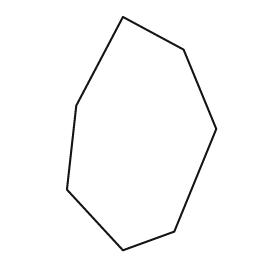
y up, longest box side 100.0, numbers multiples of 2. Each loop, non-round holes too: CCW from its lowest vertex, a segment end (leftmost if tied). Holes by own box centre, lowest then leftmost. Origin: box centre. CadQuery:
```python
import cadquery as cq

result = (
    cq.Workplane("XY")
    .moveTo(-8.0, -50.0)
    .lineTo(14.0, -42.0)
    .lineTo(32.0, 2.0)
    .lineTo(18.0, 36.0)
    .lineTo(-8.0, 50.0)
    .lineTo(-28.0, 12.0)
    .lineTo(-32.0, -24.0)
    .close()
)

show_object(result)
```